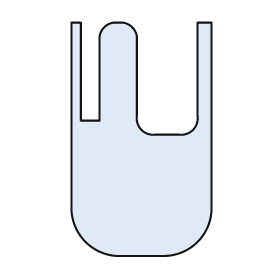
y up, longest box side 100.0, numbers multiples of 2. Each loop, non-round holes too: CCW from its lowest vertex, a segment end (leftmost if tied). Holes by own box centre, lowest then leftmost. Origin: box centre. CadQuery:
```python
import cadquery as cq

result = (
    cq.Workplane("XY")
    .moveTo(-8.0, -50.0)
    .lineTo(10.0, -50.0)
    .threePointArc((24.0, -44.0), (30.0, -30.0))
    .lineTo(30.0, 50.0)
    .lineTo(24.0, 50.0)
    .lineTo(24.0, 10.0)
    .threePointArc((22.0, 4.0), (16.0, 2.0))
    .lineTo(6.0, 2.0)
    .threePointArc((0.0, 4.0), (-2.0, 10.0))
    .lineTo(-2.0, 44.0)
    .threePointArc((-4.0, 48.0), (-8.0, 50.0))
    .lineTo(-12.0, 50.0)
    .threePointArc((-16.0, 48.0), (-18.0, 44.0))
    .lineTo(-18.0, 8.0)
    .lineTo(-26.0, 8.0)
    .lineTo(-26.0, 50.0)
    .lineTo(-30.0, 50.0)
    .lineTo(-30.0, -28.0)
    .threePointArc((-24.0, -44.0), (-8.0, -50.0))
    .close()
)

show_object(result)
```